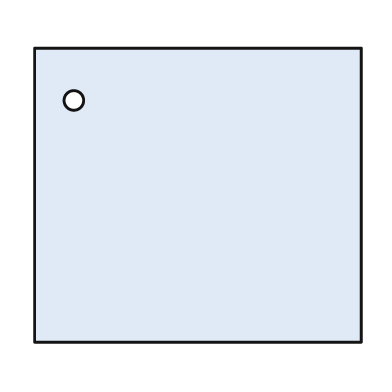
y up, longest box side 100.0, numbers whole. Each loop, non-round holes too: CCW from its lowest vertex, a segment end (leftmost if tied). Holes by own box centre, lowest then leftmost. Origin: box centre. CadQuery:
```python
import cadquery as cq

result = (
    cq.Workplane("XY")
    .moveTo(-50.0, -45.0)
    .lineTo(50.0, -45.0)
    .lineTo(50.0, 45.0)
    .lineTo(-50.0, 45.0)
    .close()
    .moveTo(-38.0, 29.0)
    .circle(3.0)
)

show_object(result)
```